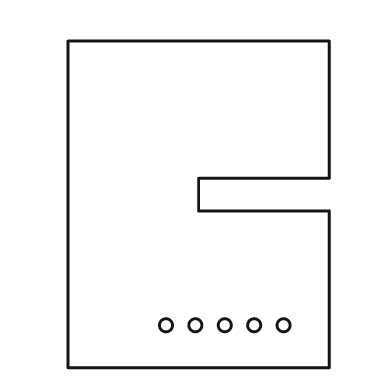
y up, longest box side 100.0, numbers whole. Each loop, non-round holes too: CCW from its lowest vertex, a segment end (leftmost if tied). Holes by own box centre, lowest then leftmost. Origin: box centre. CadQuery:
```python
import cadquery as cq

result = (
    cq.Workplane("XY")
    .moveTo(-40.0, -50.0)
    .lineTo(40.0, -50.0)
    .lineTo(40.0, -2.0)
    .lineTo(0.0, -2.0)
    .lineTo(0.0, 8.0)
    .lineTo(40.0, 8.0)
    .lineTo(40.0, 50.0)
    .lineTo(-40.0, 50.0)
    .close()
    .moveTo(-10.0, -37.0)
    .circle(2.0)
    .moveTo(-1.0, -37.0)
    .circle(2.0)
    .moveTo(8.0, -37.0)
    .circle(2.0)
    .moveTo(17.0, -37.0)
    .circle(2.0)
    .moveTo(26.0, -37.0)
    .circle(2.0)
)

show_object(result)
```